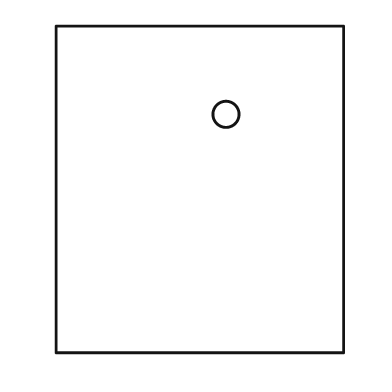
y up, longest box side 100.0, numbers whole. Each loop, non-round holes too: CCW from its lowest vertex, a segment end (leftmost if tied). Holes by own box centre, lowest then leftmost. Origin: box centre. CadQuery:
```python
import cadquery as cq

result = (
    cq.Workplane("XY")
    .moveTo(-44.0, -50.0)
    .lineTo(44.0, -50.0)
    .lineTo(44.0, 50.0)
    .lineTo(-44.0, 50.0)
    .close()
    .moveTo(8.0, 23.0)
    .circle(4.0)
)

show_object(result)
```